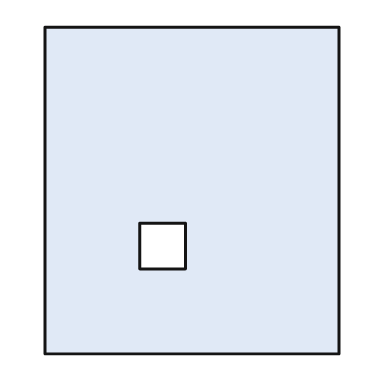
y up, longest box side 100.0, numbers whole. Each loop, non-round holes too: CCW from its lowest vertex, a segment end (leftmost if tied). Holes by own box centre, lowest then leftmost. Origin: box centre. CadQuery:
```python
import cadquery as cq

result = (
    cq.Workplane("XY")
    .moveTo(-45.0, -50.0)
    .lineTo(45.0, -50.0)
    .lineTo(45.0, 50.0)
    .lineTo(-45.0, 50.0)
    .close()
    .moveTo(-16.0, -24.0)
    .lineTo(-2.0, -24.0)
    .lineTo(-2.0, -10.0)
    .lineTo(-16.0, -10.0)
    .close()
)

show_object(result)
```